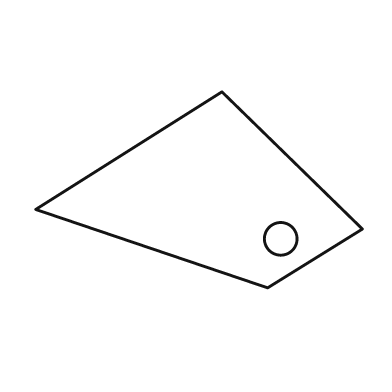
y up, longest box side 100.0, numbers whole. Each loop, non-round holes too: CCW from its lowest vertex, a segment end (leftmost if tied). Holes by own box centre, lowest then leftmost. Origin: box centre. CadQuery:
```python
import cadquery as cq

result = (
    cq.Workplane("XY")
    .moveTo(21.0, -30.0)
    .lineTo(50.0, -12.0)
    .lineTo(7.0, 30.0)
    .lineTo(-50.0, -6.0)
    .close()
    .moveTo(25.0, -15.0)
    .circle(5.0)
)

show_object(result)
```